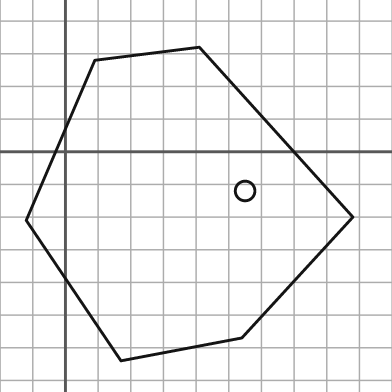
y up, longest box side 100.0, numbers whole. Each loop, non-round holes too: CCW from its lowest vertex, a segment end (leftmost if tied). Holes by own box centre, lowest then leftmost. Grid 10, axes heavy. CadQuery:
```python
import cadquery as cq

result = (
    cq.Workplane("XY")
    .moveTo(17.0, -64.0)
    .lineTo(54.0, -57.0)
    .lineTo(88.0, -20.0)
    .lineTo(41.0, 32.0)
    .lineTo(9.0, 28.0)
    .lineTo(-12.0, -21.0)
    .close()
    .moveTo(55.0, -12.0)
    .circle(3.0)
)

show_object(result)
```